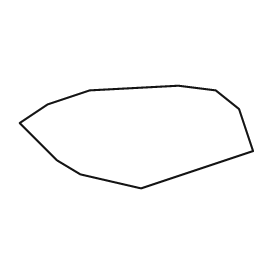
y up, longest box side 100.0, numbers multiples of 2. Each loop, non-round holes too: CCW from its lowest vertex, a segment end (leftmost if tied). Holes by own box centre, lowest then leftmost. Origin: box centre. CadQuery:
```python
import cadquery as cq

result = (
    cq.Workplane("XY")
    .moveTo(2.0, -22.0)
    .lineTo(50.0, -6.0)
    .lineTo(44.0, 12.0)
    .lineTo(34.0, 20.0)
    .lineTo(18.0, 22.0)
    .lineTo(-20.0, 20.0)
    .lineTo(-38.0, 14.0)
    .lineTo(-50.0, 6.0)
    .lineTo(-34.0, -10.0)
    .lineTo(-24.0, -16.0)
    .close()
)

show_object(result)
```